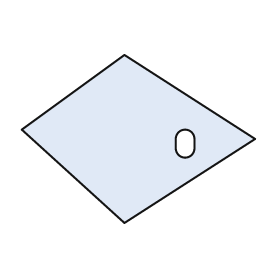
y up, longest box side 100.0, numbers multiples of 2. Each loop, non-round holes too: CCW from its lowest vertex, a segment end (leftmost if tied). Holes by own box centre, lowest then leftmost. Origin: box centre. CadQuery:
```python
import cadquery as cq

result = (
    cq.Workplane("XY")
    .moveTo(-6.0, -36.0)
    .lineTo(50.0, 0.0)
    .lineTo(-6.0, 36.0)
    .lineTo(-50.0, 4.0)
    .close()
    .moveTo(16.0, -4.0)
    .threePointArc((20.0, -8.0), (24.0, -4.0))
    .lineTo(24.0, 0.0)
    .threePointArc((20.0, 4.0), (16.0, 0.0))
    .close()
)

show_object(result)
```